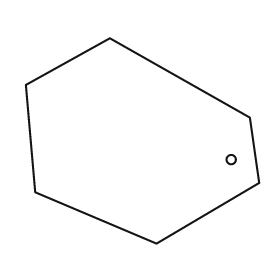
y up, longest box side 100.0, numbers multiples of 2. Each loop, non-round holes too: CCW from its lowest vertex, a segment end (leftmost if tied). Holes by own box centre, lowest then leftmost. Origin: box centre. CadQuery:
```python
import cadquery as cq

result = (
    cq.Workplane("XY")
    .moveTo(6.0, -44.0)
    .lineTo(50.0, -18.0)
    .lineTo(46.0, 10.0)
    .lineTo(-14.0, 44.0)
    .lineTo(-50.0, 24.0)
    .lineTo(-46.0, -22.0)
    .close()
    .moveTo(38.0, -8.0)
    .circle(2.0)
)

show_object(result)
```